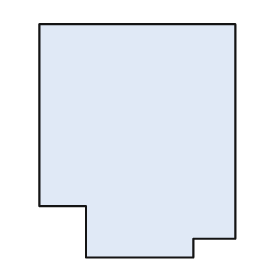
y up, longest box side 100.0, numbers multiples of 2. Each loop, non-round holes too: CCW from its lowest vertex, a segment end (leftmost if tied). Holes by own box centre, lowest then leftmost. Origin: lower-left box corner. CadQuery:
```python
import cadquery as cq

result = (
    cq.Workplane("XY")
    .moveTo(20.0, 0.0)
    .lineTo(66.0, 0.0)
    .lineTo(66.0, 8.0)
    .lineTo(84.0, 8.0)
    .lineTo(84.0, 100.0)
    .lineTo(0.0, 100.0)
    .lineTo(0.0, 22.0)
    .lineTo(20.0, 22.0)
    .close()
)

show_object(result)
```